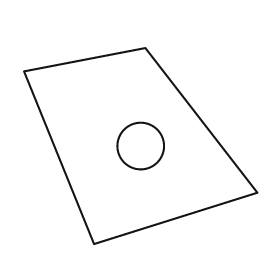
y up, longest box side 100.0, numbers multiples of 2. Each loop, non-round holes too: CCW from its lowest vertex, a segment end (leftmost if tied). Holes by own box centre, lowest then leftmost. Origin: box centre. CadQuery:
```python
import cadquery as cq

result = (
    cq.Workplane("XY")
    .moveTo(-20.0, -42.0)
    .lineTo(50.0, -20.0)
    .lineTo(2.0, 42.0)
    .lineTo(-50.0, 32.0)
    .close()
    .moveTo(0.0, 0.0)
    .circle(10.0)
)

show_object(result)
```